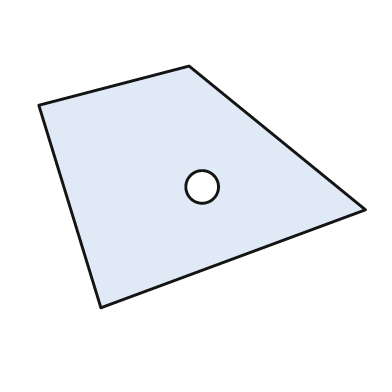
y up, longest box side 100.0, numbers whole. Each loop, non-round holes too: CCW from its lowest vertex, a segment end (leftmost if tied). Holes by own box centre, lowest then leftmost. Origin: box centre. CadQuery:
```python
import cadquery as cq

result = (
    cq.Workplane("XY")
    .moveTo(-31.0, -37.0)
    .lineTo(50.0, -7.0)
    .lineTo(-4.0, 37.0)
    .lineTo(-50.0, 25.0)
    .close()
    .moveTo(0.0, 0.0)
    .circle(5.0)
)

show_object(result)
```